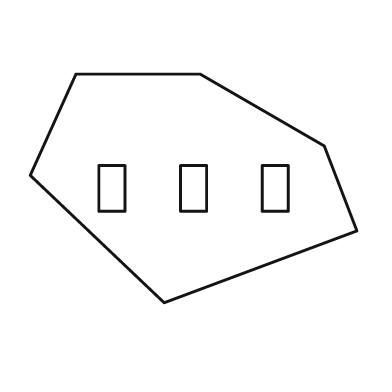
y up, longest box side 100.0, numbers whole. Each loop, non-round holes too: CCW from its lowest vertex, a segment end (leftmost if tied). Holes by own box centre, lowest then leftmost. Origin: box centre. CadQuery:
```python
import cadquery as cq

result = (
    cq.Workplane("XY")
    .moveTo(-9.0, -35.0)
    .lineTo(50.0, -13.0)
    .lineTo(40.0, 13.0)
    .lineTo(2.0, 35.0)
    .lineTo(-36.0, 35.0)
    .lineTo(-50.0, 4.0)
    .close()
    .moveTo(-29.0, -7.0)
    .lineTo(-21.0, -7.0)
    .lineTo(-21.0, 7.0)
    .lineTo(-29.0, 7.0)
    .close()
    .moveTo(-4.0, -7.0)
    .lineTo(4.0, -7.0)
    .lineTo(4.0, 7.0)
    .lineTo(-4.0, 7.0)
    .close()
    .moveTo(21.0, -7.0)
    .lineTo(29.0, -7.0)
    .lineTo(29.0, 7.0)
    .lineTo(21.0, 7.0)
    .close()
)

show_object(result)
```